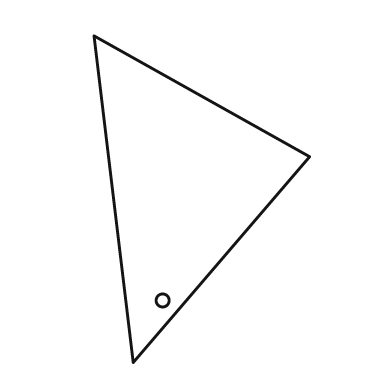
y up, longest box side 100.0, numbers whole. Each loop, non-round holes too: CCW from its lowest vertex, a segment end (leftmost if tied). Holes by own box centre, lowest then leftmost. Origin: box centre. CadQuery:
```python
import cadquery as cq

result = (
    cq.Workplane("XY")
    .moveTo(-21.0, -50.0)
    .lineTo(33.0, 13.0)
    .lineTo(-33.0, 50.0)
    .close()
    .moveTo(-12.0, -31.0)
    .circle(2.0)
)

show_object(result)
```